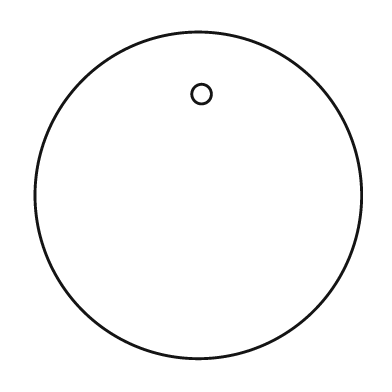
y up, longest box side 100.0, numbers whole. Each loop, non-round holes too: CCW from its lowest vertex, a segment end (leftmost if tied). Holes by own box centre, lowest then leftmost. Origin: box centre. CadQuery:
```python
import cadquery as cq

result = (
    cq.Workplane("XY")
    .moveTo(0.0, 0.0)
    .circle(50.0)
    .moveTo(1.0, 31.0)
    .circle(3.0)
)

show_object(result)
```